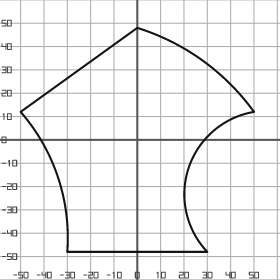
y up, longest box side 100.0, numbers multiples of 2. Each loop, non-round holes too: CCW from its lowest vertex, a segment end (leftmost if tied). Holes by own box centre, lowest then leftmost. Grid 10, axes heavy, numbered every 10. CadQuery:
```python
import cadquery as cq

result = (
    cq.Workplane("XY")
    .moveTo(-30.0, -48.0)
    .lineTo(30.0, -48.0)
    .threePointArc((22.0, -12.0), (50.0, 12.0))
    .threePointArc((28.0, 34.0), (0.0, 48.0))
    .lineTo(-50.0, 12.0)
    .threePointArc((-34.0, -16.0), (-30.0, -48.0))
    .close()
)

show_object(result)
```